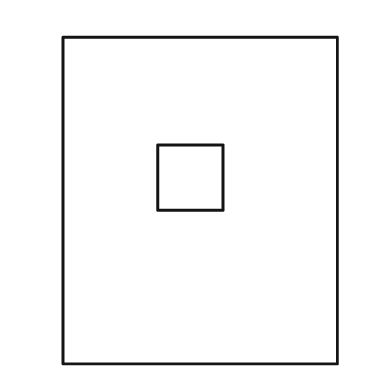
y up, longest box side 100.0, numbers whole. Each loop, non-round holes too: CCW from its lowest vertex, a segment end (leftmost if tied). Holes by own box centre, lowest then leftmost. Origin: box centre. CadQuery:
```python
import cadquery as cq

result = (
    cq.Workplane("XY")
    .moveTo(-42.0, -50.0)
    .lineTo(42.0, -50.0)
    .lineTo(42.0, 50.0)
    .lineTo(-42.0, 50.0)
    .close()
    .moveTo(-13.0, -3.0)
    .lineTo(7.0, -3.0)
    .lineTo(7.0, 17.0)
    .lineTo(-13.0, 17.0)
    .close()
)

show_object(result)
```